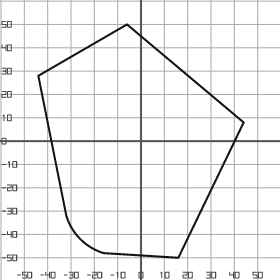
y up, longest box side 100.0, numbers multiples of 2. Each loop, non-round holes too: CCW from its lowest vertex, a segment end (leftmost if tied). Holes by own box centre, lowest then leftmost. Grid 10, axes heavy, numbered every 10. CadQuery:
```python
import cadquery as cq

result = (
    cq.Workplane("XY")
    .moveTo(16.0, -50.0)
    .lineTo(44.0, 8.0)
    .lineTo(-6.0, 50.0)
    .lineTo(-44.0, 28.0)
    .lineTo(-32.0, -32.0)
    .threePointArc((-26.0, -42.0), (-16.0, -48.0))
    .close()
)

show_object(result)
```